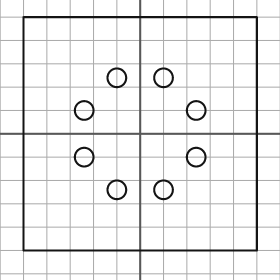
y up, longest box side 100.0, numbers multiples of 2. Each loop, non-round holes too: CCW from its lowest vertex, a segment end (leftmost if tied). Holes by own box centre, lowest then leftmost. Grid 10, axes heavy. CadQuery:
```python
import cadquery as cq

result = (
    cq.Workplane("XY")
    .moveTo(-50.0, -50.0)
    .lineTo(50.0, -50.0)
    .lineTo(50.0, 50.0)
    .lineTo(-50.0, 50.0)
    .close()
    .moveTo(-10.0, -24.0)
    .circle(4.0)
    .moveTo(10.0, -24.0)
    .circle(4.0)
    .moveTo(-24.0, -10.0)
    .circle(4.0)
    .moveTo(24.0, -10.0)
    .circle(4.0)
    .moveTo(-24.0, 10.0)
    .circle(4.0)
    .moveTo(24.0, 10.0)
    .circle(4.0)
    .moveTo(-10.0, 24.0)
    .circle(4.0)
    .moveTo(10.0, 24.0)
    .circle(4.0)
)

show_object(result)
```